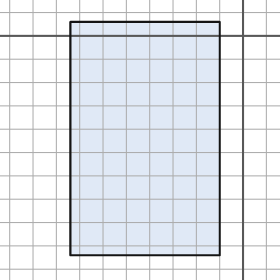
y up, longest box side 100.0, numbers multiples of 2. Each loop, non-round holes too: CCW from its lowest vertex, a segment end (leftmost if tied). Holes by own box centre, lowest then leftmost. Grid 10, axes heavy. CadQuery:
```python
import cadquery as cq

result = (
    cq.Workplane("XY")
    .moveTo(-74.0, -94.0)
    .lineTo(-10.0, -94.0)
    .lineTo(-10.0, 6.0)
    .lineTo(-74.0, 6.0)
    .close()
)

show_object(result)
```